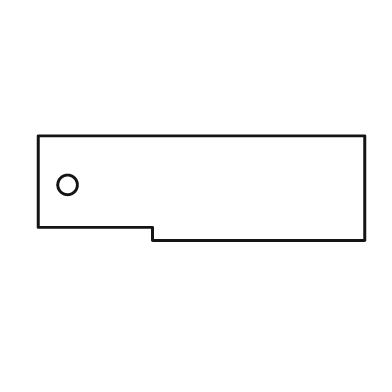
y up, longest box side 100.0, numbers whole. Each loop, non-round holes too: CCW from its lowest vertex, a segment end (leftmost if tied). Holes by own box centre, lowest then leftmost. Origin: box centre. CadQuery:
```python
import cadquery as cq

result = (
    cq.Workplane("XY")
    .moveTo(-15.0, -16.0)
    .lineTo(50.0, -16.0)
    .lineTo(50.0, 16.0)
    .lineTo(-50.0, 16.0)
    .lineTo(-50.0, -12.0)
    .lineTo(-15.0, -12.0)
    .close()
    .moveTo(-41.0, 1.0)
    .circle(3.0)
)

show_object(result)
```